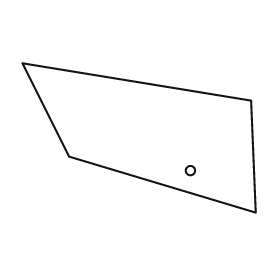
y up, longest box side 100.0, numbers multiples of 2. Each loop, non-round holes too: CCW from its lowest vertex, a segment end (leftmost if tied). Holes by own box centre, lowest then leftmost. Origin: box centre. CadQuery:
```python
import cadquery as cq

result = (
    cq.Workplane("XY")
    .moveTo(50.0, -32.0)
    .lineTo(48.0, 16.0)
    .lineTo(-50.0, 32.0)
    .lineTo(-30.0, -8.0)
    .close()
    .moveTo(22.0, -14.0)
    .circle(2.0)
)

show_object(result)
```